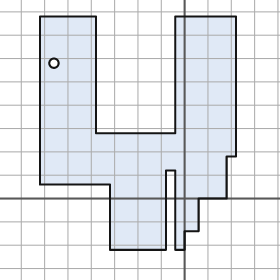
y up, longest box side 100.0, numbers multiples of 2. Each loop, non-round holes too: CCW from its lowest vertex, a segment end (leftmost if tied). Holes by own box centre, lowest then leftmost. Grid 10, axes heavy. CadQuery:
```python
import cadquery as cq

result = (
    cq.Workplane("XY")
    .moveTo(-32.0, -22.0)
    .lineTo(-8.0, -22.0)
    .lineTo(-8.0, 12.0)
    .lineTo(-4.0, 12.0)
    .lineTo(-4.0, -22.0)
    .lineTo(0.0, -22.0)
    .lineTo(0.0, -14.0)
    .lineTo(6.0, -14.0)
    .lineTo(6.0, 0.0)
    .lineTo(18.0, 0.0)
    .lineTo(18.0, 18.0)
    .lineTo(22.0, 18.0)
    .lineTo(22.0, 78.0)
    .lineTo(-4.0, 78.0)
    .lineTo(-4.0, 28.0)
    .lineTo(-38.0, 28.0)
    .lineTo(-38.0, 78.0)
    .lineTo(-62.0, 78.0)
    .lineTo(-62.0, 6.0)
    .lineTo(-32.0, 6.0)
    .close()
    .moveTo(-56.0, 58.0)
    .circle(2.0)
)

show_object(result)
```